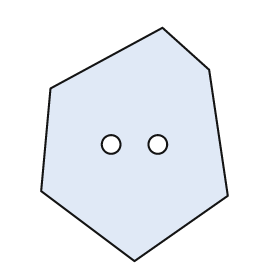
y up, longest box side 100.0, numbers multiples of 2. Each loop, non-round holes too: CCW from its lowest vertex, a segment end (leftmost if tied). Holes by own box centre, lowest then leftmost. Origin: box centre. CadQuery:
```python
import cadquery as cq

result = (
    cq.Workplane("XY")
    .moveTo(0.0, -50.0)
    .lineTo(40.0, -22.0)
    .lineTo(32.0, 32.0)
    .lineTo(12.0, 50.0)
    .lineTo(-36.0, 24.0)
    .lineTo(-40.0, -20.0)
    .close()
    .moveTo(-10.0, 0.0)
    .circle(4.0)
    .moveTo(10.0, 0.0)
    .circle(4.0)
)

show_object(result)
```